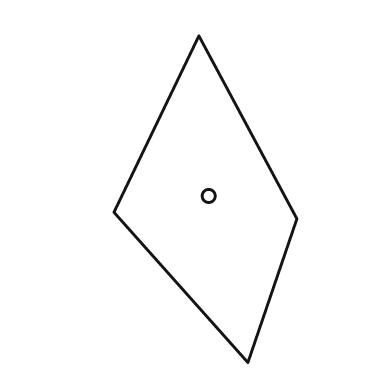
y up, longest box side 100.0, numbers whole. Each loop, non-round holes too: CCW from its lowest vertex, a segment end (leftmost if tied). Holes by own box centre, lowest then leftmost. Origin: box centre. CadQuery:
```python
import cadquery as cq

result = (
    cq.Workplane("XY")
    .moveTo(13.0, -50.0)
    .lineTo(28.0, -6.0)
    .lineTo(-2.0, 50.0)
    .lineTo(-28.0, -4.0)
    .close()
    .moveTo(1.0, 1.0)
    .circle(2.0)
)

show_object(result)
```